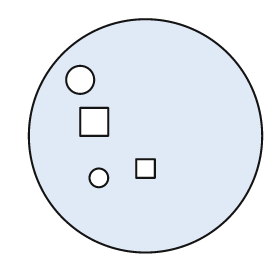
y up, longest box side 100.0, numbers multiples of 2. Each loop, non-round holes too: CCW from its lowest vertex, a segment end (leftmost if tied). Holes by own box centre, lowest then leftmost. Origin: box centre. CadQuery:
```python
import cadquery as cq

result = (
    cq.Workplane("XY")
    .moveTo(0.0, 0.0)
    .circle(50.0)
    .moveTo(-20.0, -18.0)
    .circle(4.0)
    .moveTo(-4.0, -18.0)
    .lineTo(4.0, -18.0)
    .lineTo(4.0, -10.0)
    .lineTo(-4.0, -10.0)
    .close()
    .moveTo(-28.0, 0.0)
    .lineTo(-16.0, 0.0)
    .lineTo(-16.0, 12.0)
    .lineTo(-28.0, 12.0)
    .close()
    .moveTo(-28.0, 24.0)
    .circle(6.0)
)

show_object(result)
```